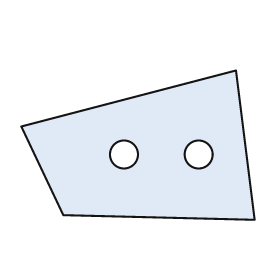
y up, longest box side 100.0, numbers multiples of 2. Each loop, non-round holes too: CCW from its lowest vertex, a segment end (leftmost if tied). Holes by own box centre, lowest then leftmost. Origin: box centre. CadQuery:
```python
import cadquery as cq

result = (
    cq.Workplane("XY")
    .moveTo(50.0, -32.0)
    .lineTo(42.0, 32.0)
    .lineTo(-50.0, 8.0)
    .lineTo(-32.0, -30.0)
    .close()
    .moveTo(-6.0, -4.0)
    .circle(6.0)
    .moveTo(26.0, -4.0)
    .circle(6.0)
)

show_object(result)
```